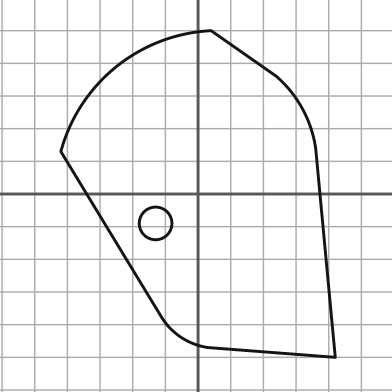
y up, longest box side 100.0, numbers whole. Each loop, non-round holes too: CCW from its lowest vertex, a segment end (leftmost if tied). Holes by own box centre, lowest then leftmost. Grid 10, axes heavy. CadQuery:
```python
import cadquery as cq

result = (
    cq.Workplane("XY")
    .moveTo(42.0, -50.0)
    .lineTo(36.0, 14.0)
    .threePointArc((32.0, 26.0), (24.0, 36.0))
    .lineTo(4.0, 50.0)
    .threePointArc((-25.0, 39.0), (-42.0, 13.0))
    .lineTo(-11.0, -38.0)
    .threePointArc((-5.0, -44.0), (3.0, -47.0))
    .close()
    .moveTo(-13.0, -9.0)
    .circle(5.0)
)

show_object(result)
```